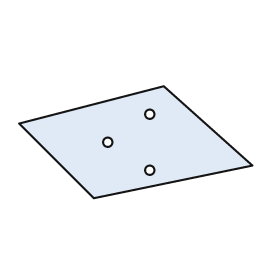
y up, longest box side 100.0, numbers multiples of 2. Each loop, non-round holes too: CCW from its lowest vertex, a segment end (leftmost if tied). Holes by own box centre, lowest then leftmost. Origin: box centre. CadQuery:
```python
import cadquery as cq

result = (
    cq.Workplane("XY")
    .moveTo(-18.0, -24.0)
    .lineTo(50.0, -10.0)
    .lineTo(12.0, 24.0)
    .lineTo(-50.0, 8.0)
    .close()
    .moveTo(6.0, -12.0)
    .circle(2.0)
    .moveTo(-12.0, 0.0)
    .circle(2.0)
    .moveTo(6.0, 12.0)
    .circle(2.0)
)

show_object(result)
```